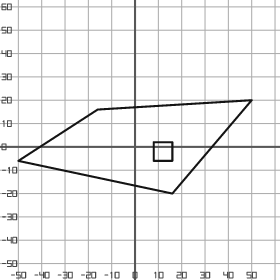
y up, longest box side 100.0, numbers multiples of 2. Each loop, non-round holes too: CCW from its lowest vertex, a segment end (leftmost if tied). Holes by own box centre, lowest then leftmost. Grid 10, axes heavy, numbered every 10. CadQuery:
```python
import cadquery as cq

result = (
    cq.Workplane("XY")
    .moveTo(16.0, -20.0)
    .lineTo(50.0, 20.0)
    .lineTo(-16.0, 16.0)
    .lineTo(-50.0, -6.0)
    .close()
    .moveTo(8.0, -6.0)
    .lineTo(16.0, -6.0)
    .lineTo(16.0, 2.0)
    .lineTo(8.0, 2.0)
    .close()
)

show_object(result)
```